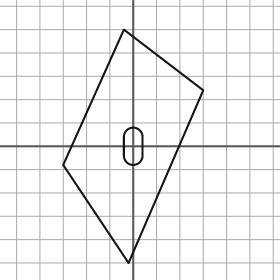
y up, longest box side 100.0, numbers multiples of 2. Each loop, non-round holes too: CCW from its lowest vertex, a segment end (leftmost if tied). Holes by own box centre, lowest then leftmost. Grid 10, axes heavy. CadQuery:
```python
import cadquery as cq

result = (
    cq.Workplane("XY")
    .moveTo(-2.0, -50.0)
    .lineTo(30.0, 24.0)
    .lineTo(-4.0, 50.0)
    .lineTo(-30.0, -8.0)
    .close()
    .moveTo(-4.0, -4.0)
    .threePointArc((0.0, -8.0), (4.0, -4.0))
    .lineTo(4.0, 4.0)
    .threePointArc((0.0, 8.0), (-4.0, 4.0))
    .close()
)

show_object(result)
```